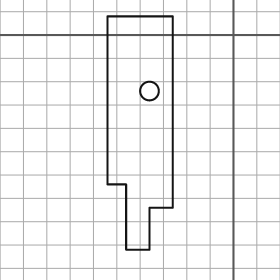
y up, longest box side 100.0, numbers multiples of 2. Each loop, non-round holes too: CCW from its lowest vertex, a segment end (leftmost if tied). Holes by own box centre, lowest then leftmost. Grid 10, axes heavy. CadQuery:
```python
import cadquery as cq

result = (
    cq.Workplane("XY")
    .moveTo(-46.0, -92.0)
    .lineTo(-36.0, -92.0)
    .lineTo(-36.0, -74.0)
    .lineTo(-26.0, -74.0)
    .lineTo(-26.0, 8.0)
    .lineTo(-54.0, 8.0)
    .lineTo(-54.0, -64.0)
    .lineTo(-46.0, -64.0)
    .close()
    .moveTo(-36.0, -24.0)
    .circle(4.0)
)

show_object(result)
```